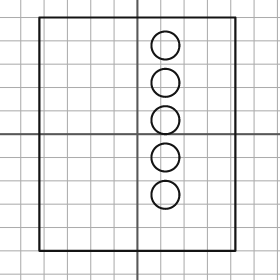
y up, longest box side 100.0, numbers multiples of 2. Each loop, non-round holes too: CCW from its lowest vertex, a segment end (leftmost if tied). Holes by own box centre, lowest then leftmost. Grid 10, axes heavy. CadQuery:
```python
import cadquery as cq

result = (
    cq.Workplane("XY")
    .moveTo(-42.0, -50.0)
    .lineTo(42.0, -50.0)
    .lineTo(42.0, 50.0)
    .lineTo(-42.0, 50.0)
    .close()
    .moveTo(12.0, -26.0)
    .circle(6.0)
    .moveTo(12.0, -10.0)
    .circle(6.0)
    .moveTo(12.0, 6.0)
    .circle(6.0)
    .moveTo(12.0, 22.0)
    .circle(6.0)
    .moveTo(12.0, 38.0)
    .circle(6.0)
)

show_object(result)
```